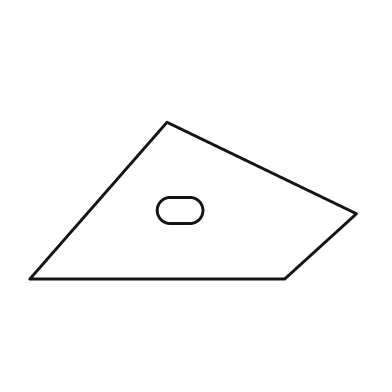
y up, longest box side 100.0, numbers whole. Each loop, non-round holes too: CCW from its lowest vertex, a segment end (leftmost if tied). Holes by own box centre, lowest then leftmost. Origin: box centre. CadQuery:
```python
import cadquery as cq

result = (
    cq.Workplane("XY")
    .moveTo(-50.0, -24.0)
    .lineTo(28.0, -24.0)
    .lineTo(50.0, -4.0)
    .lineTo(-8.0, 24.0)
    .close()
    .moveTo(-7.0, -7.0)
    .lineTo(-1.0, -7.0)
    .threePointArc((3.0, -3.0), (-1.0, 1.0))
    .lineTo(-7.0, 1.0)
    .threePointArc((-11.0, -3.0), (-7.0, -7.0))
    .close()
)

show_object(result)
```